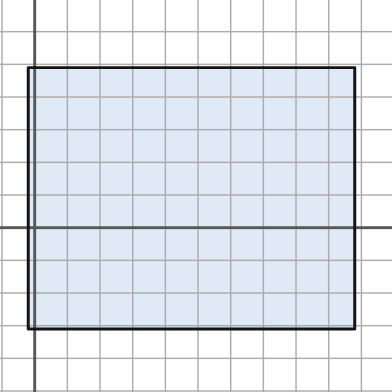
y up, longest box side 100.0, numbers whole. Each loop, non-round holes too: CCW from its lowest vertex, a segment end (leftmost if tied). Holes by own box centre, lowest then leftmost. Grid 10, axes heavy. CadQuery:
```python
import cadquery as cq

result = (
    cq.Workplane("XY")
    .moveTo(-2.0, -31.0)
    .lineTo(98.0, -31.0)
    .lineTo(98.0, 49.0)
    .lineTo(-2.0, 49.0)
    .close()
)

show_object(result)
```